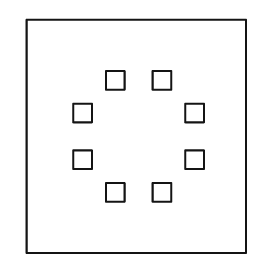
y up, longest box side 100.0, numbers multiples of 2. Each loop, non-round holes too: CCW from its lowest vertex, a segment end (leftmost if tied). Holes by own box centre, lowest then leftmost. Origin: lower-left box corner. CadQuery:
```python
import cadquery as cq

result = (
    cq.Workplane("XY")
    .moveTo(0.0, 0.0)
    .lineTo(94.0, 0.0)
    .lineTo(94.0, 100.0)
    .lineTo(0.0, 100.0)
    .close()
    .moveTo(34.0, 22.0)
    .lineTo(42.0, 22.0)
    .lineTo(42.0, 30.0)
    .lineTo(34.0, 30.0)
    .close()
    .moveTo(54.0, 22.0)
    .lineTo(62.0, 22.0)
    .lineTo(62.0, 30.0)
    .lineTo(54.0, 30.0)
    .close()
    .moveTo(20.0, 36.0)
    .lineTo(28.0, 36.0)
    .lineTo(28.0, 44.0)
    .lineTo(20.0, 44.0)
    .close()
    .moveTo(68.0, 36.0)
    .lineTo(76.0, 36.0)
    .lineTo(76.0, 44.0)
    .lineTo(68.0, 44.0)
    .close()
    .moveTo(20.0, 56.0)
    .lineTo(28.0, 56.0)
    .lineTo(28.0, 64.0)
    .lineTo(20.0, 64.0)
    .close()
    .moveTo(68.0, 56.0)
    .lineTo(76.0, 56.0)
    .lineTo(76.0, 64.0)
    .lineTo(68.0, 64.0)
    .close()
    .moveTo(34.0, 70.0)
    .lineTo(42.0, 70.0)
    .lineTo(42.0, 78.0)
    .lineTo(34.0, 78.0)
    .close()
    .moveTo(54.0, 70.0)
    .lineTo(62.0, 70.0)
    .lineTo(62.0, 78.0)
    .lineTo(54.0, 78.0)
    .close()
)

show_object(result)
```